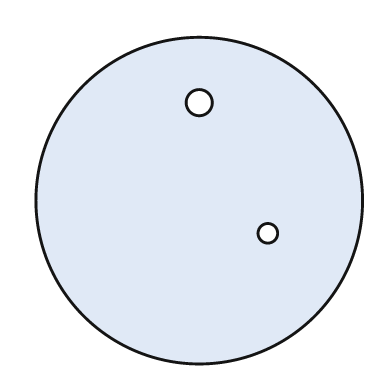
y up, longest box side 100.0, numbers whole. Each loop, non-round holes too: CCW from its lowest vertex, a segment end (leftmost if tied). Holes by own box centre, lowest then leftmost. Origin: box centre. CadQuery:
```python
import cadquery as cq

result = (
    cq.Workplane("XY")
    .moveTo(0.0, 0.0)
    .circle(50.0)
    .moveTo(21.0, -10.0)
    .circle(3.0)
    .moveTo(0.0, 30.0)
    .circle(4.0)
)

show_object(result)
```